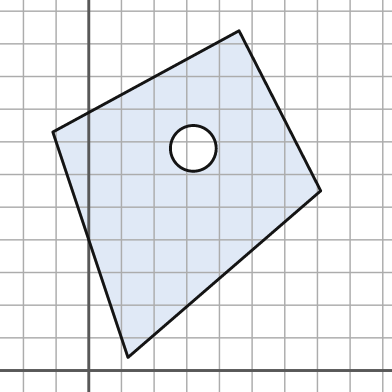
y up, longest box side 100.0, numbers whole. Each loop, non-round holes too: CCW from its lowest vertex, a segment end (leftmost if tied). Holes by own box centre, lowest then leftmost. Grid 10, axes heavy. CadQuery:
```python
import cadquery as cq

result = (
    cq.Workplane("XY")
    .moveTo(12.0, 4.0)
    .lineTo(71.0, 55.0)
    .lineTo(46.0, 104.0)
    .lineTo(-11.0, 73.0)
    .close()
    .moveTo(32.0, 68.0)
    .circle(7.0)
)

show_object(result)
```